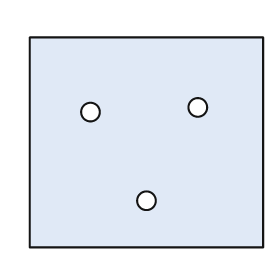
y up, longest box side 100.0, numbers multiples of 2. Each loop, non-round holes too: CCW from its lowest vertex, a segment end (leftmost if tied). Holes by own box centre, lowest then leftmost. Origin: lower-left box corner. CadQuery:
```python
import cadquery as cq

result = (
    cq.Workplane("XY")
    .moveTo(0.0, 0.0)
    .lineTo(100.0, 0.0)
    .lineTo(100.0, 90.0)
    .lineTo(0.0, 90.0)
    .close()
    .moveTo(50.0, 20.0)
    .circle(4.0)
    .moveTo(26.0, 58.0)
    .circle(4.0)
    .moveTo(72.0, 60.0)
    .circle(4.0)
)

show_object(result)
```